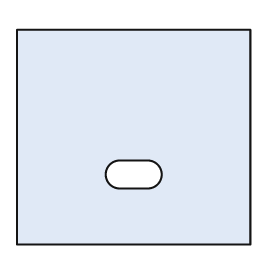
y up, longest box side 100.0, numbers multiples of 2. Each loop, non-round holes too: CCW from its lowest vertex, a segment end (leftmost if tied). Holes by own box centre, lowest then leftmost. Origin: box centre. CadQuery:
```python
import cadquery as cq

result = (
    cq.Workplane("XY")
    .moveTo(-50.0, -46.0)
    .lineTo(50.0, -46.0)
    .lineTo(50.0, 46.0)
    .lineTo(-50.0, 46.0)
    .close()
    .moveTo(-6.0, -22.0)
    .lineTo(6.0, -22.0)
    .threePointArc((12.0, -16.0), (6.0, -10.0))
    .lineTo(-6.0, -10.0)
    .threePointArc((-12.0, -16.0), (-6.0, -22.0))
    .close()
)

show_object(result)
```